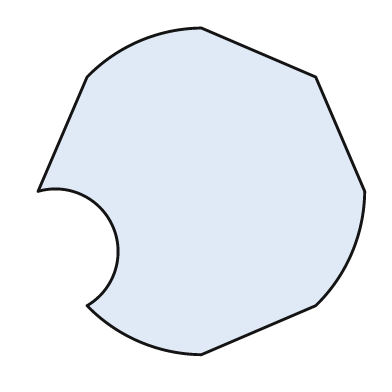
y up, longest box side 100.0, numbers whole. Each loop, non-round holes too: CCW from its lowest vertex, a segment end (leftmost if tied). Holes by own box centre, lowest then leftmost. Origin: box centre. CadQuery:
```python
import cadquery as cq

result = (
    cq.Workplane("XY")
    .moveTo(0.0, -50.0)
    .lineTo(35.0, -35.0)
    .threePointArc((46.0, -19.0), (50.0, 0.0))
    .lineTo(35.0, 35.0)
    .lineTo(0.0, 50.0)
    .threePointArc((-19.0, 46.0), (-35.0, 35.0))
    .lineTo(-50.0, 0.0)
    .threePointArc((-27.0, -11.0), (-35.0, -35.0))
    .threePointArc((-19.0, -46.0), (0.0, -50.0))
    .close()
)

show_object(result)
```